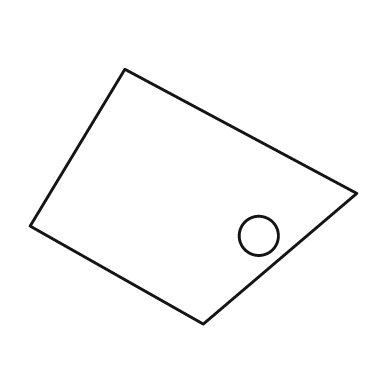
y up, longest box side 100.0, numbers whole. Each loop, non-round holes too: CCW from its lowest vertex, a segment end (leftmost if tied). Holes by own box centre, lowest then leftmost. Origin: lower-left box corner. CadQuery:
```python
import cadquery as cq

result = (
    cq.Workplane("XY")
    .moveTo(53.0, 0.0)
    .lineTo(100.0, 40.0)
    .lineTo(29.0, 78.0)
    .lineTo(0.0, 30.0)
    .close()
    .moveTo(70.0, 27.0)
    .circle(6.0)
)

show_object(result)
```